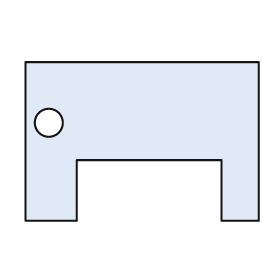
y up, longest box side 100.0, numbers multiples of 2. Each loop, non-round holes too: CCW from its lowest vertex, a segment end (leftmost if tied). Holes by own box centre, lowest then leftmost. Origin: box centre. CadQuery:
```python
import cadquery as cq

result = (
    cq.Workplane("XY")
    .moveTo(-50.0, -34.0)
    .lineTo(-28.0, -34.0)
    .lineTo(-28.0, -8.0)
    .lineTo(34.0, -8.0)
    .lineTo(34.0, -34.0)
    .lineTo(50.0, -34.0)
    .lineTo(50.0, 34.0)
    .lineTo(-50.0, 34.0)
    .close()
    .moveTo(-40.0, 8.0)
    .circle(6.0)
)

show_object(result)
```